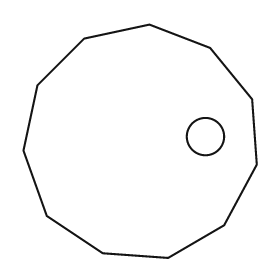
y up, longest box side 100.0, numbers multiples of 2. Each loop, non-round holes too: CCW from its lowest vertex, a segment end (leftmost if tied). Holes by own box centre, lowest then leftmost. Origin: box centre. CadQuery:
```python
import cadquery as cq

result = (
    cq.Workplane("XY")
    .moveTo(12.0, -50.0)
    .lineTo(36.0, -36.0)
    .lineTo(50.0, -10.0)
    .lineTo(48.0, 18.0)
    .lineTo(30.0, 40.0)
    .lineTo(4.0, 50.0)
    .lineTo(-24.0, 44.0)
    .lineTo(-44.0, 24.0)
    .lineTo(-50.0, -4.0)
    .lineTo(-40.0, -32.0)
    .lineTo(-16.0, -48.0)
    .close()
    .moveTo(28.0, 2.0)
    .circle(8.0)
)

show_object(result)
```